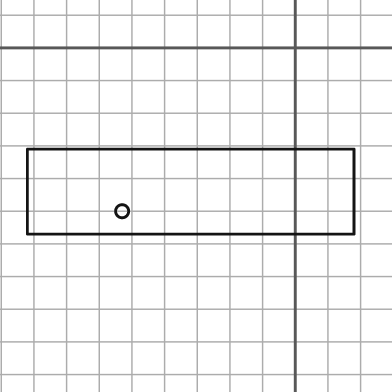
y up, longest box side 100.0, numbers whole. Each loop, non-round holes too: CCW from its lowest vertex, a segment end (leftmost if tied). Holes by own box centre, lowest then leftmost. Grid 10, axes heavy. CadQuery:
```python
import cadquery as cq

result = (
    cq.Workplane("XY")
    .moveTo(-82.0, -57.0)
    .lineTo(18.0, -57.0)
    .lineTo(18.0, -31.0)
    .lineTo(-82.0, -31.0)
    .close()
    .moveTo(-53.0, -50.0)
    .circle(2.0)
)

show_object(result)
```